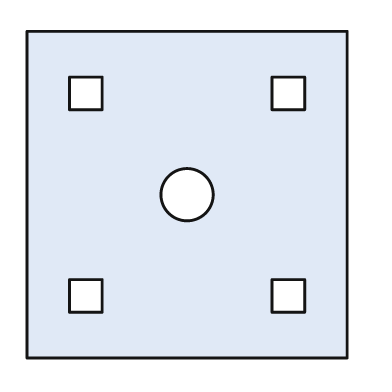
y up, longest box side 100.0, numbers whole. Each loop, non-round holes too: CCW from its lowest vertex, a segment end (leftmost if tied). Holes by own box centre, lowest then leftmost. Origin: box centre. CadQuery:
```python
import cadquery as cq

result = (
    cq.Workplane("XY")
    .moveTo(-49.0, -50.0)
    .lineTo(49.0, -50.0)
    .lineTo(49.0, 50.0)
    .lineTo(-49.0, 50.0)
    .close()
    .moveTo(-36.0, -36.0)
    .lineTo(-26.0, -36.0)
    .lineTo(-26.0, -26.0)
    .lineTo(-36.0, -26.0)
    .close()
    .moveTo(26.0, -36.0)
    .lineTo(36.0, -36.0)
    .lineTo(36.0, -26.0)
    .lineTo(26.0, -26.0)
    .close()
    .moveTo(0.0, 0.0)
    .circle(8.0)
    .moveTo(-36.0, 26.0)
    .lineTo(-26.0, 26.0)
    .lineTo(-26.0, 36.0)
    .lineTo(-36.0, 36.0)
    .close()
    .moveTo(26.0, 26.0)
    .lineTo(36.0, 26.0)
    .lineTo(36.0, 36.0)
    .lineTo(26.0, 36.0)
    .close()
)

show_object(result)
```